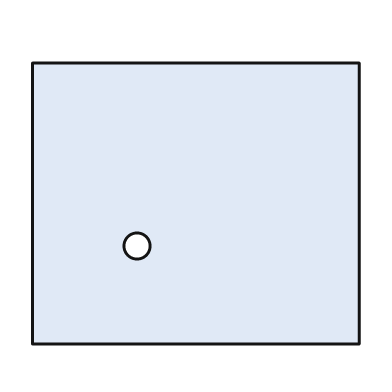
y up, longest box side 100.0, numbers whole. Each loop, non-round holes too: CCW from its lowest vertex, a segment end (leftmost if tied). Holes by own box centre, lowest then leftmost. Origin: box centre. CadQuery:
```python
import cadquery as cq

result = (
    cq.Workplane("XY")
    .moveTo(-50.0, -43.0)
    .lineTo(50.0, -43.0)
    .lineTo(50.0, 43.0)
    .lineTo(-50.0, 43.0)
    .close()
    .moveTo(-18.0, -13.0)
    .circle(4.0)
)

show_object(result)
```